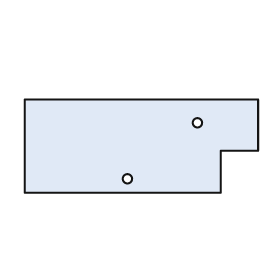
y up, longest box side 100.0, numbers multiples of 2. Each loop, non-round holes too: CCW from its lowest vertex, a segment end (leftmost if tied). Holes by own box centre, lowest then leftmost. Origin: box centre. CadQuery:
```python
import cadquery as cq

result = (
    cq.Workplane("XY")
    .moveTo(-50.0, -20.0)
    .lineTo(34.0, -20.0)
    .lineTo(34.0, -2.0)
    .lineTo(50.0, -2.0)
    .lineTo(50.0, 20.0)
    .lineTo(-50.0, 20.0)
    .close()
    .moveTo(-6.0, -14.0)
    .circle(2.0)
    .moveTo(24.0, 10.0)
    .circle(2.0)
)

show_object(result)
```